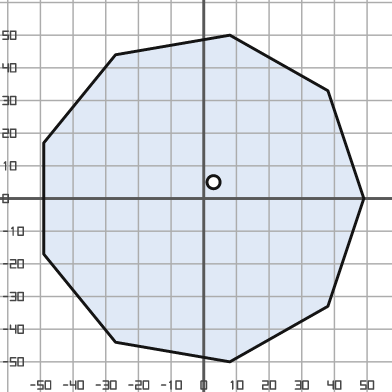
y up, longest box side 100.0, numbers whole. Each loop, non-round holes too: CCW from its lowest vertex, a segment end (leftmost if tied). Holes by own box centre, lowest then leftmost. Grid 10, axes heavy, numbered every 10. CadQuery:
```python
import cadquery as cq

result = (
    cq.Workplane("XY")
    .moveTo(8.0, -50.0)
    .lineTo(38.0, -33.0)
    .lineTo(49.0, 0.0)
    .lineTo(38.0, 33.0)
    .lineTo(8.0, 50.0)
    .lineTo(-27.0, 44.0)
    .lineTo(-49.0, 17.0)
    .lineTo(-49.0, -17.0)
    .lineTo(-27.0, -44.0)
    .close()
    .moveTo(3.0, 5.0)
    .circle(2.0)
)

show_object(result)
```